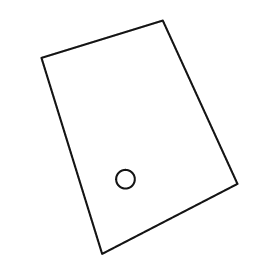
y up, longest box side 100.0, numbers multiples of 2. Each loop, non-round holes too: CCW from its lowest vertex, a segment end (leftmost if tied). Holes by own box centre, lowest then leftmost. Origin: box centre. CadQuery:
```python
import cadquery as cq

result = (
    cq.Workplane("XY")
    .moveTo(-16.0, -50.0)
    .lineTo(42.0, -20.0)
    .lineTo(10.0, 50.0)
    .lineTo(-42.0, 34.0)
    .close()
    .moveTo(-6.0, -18.0)
    .circle(4.0)
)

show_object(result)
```